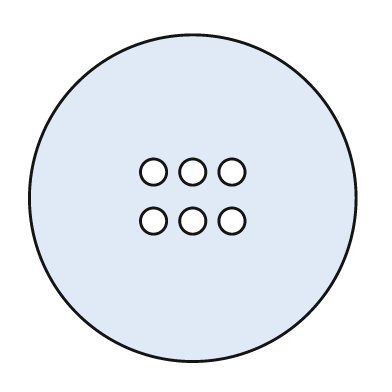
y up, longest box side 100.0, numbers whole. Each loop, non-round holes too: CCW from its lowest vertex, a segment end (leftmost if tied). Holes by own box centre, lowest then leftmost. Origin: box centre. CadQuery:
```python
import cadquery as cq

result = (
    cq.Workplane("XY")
    .moveTo(0.0, 0.0)
    .circle(50.0)
    .moveTo(-12.0, -7.0)
    .circle(4.0)
    .moveTo(0.0, -7.0)
    .circle(4.0)
    .moveTo(12.0, -7.0)
    .circle(4.0)
    .moveTo(-12.0, 8.0)
    .circle(4.0)
    .moveTo(0.0, 8.0)
    .circle(4.0)
    .moveTo(12.0, 8.0)
    .circle(4.0)
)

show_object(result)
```